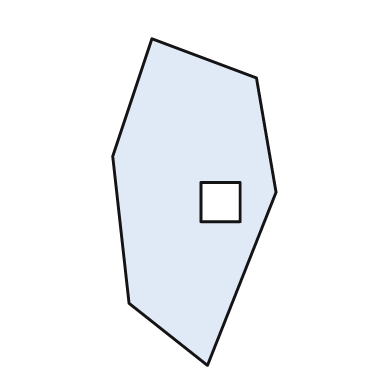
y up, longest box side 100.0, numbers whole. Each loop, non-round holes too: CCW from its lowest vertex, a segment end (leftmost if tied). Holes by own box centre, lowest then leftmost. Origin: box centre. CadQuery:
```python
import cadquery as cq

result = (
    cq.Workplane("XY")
    .moveTo(4.0, -50.0)
    .lineTo(25.0, 3.0)
    .lineTo(19.0, 38.0)
    .lineTo(-13.0, 50.0)
    .lineTo(-25.0, 14.0)
    .lineTo(-20.0, -31.0)
    .close()
    .moveTo(2.0, -6.0)
    .lineTo(14.0, -6.0)
    .lineTo(14.0, 6.0)
    .lineTo(2.0, 6.0)
    .close()
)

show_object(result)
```